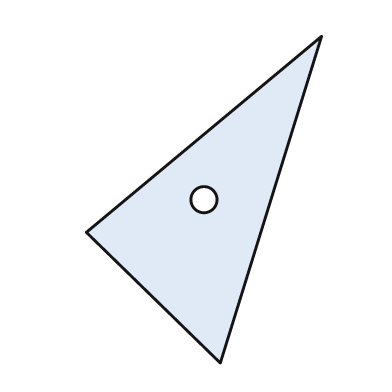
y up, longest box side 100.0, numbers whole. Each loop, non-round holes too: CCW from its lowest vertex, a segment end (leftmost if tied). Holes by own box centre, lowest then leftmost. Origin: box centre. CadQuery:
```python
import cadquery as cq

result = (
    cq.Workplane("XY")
    .moveTo(5.0, -50.0)
    .lineTo(36.0, 50.0)
    .lineTo(-36.0, -10.0)
    .close()
    .moveTo(0.0, 0.0)
    .circle(4.0)
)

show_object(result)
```